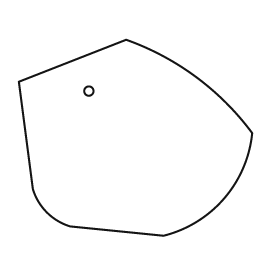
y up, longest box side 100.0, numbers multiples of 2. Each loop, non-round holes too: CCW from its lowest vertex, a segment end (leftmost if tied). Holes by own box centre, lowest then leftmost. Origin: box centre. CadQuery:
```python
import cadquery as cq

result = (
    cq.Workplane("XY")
    .moveTo(12.0, -42.0)
    .threePointArc((38.0, -26.0), (50.0, 2.0))
    .threePointArc((26.0, 26.0), (-4.0, 42.0))
    .lineTo(-50.0, 24.0)
    .lineTo(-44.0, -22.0)
    .threePointArc((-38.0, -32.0), (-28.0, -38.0))
    .close()
    .moveTo(-20.0, 20.0)
    .circle(2.0)
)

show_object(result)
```